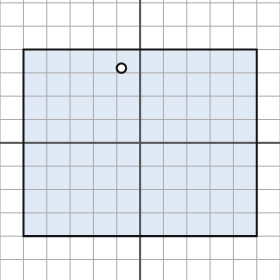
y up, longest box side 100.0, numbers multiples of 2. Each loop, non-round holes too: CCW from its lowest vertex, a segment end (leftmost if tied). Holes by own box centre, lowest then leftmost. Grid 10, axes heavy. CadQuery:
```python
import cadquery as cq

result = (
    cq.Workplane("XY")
    .moveTo(-50.0, -40.0)
    .lineTo(50.0, -40.0)
    .lineTo(50.0, 40.0)
    .lineTo(-50.0, 40.0)
    .close()
    .moveTo(-8.0, 32.0)
    .circle(2.0)
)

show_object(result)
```